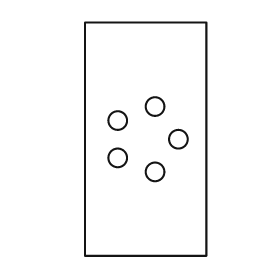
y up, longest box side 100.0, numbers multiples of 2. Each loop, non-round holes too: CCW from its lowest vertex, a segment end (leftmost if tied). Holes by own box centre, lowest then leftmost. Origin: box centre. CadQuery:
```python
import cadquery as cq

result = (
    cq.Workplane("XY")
    .moveTo(-26.0, -50.0)
    .lineTo(26.0, -50.0)
    .lineTo(26.0, 50.0)
    .lineTo(-26.0, 50.0)
    .close()
    .moveTo(4.0, -14.0)
    .circle(4.0)
    .moveTo(-12.0, -8.0)
    .circle(4.0)
    .moveTo(14.0, 0.0)
    .circle(4.0)
    .moveTo(-12.0, 8.0)
    .circle(4.0)
    .moveTo(4.0, 14.0)
    .circle(4.0)
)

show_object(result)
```